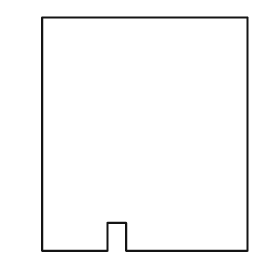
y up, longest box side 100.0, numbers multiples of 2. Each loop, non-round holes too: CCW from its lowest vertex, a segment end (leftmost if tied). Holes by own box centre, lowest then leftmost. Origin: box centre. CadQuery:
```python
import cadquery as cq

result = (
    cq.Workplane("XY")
    .moveTo(-44.0, -50.0)
    .lineTo(-16.0, -50.0)
    .lineTo(-16.0, -38.0)
    .lineTo(-8.0, -38.0)
    .lineTo(-8.0, -50.0)
    .lineTo(44.0, -50.0)
    .lineTo(44.0, 50.0)
    .lineTo(-44.0, 50.0)
    .close()
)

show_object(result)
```